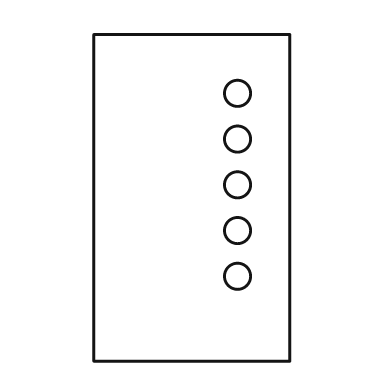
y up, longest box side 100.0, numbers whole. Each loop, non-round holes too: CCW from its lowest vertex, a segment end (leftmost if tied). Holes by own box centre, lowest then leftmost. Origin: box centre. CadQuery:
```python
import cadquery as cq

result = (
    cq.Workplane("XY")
    .moveTo(-30.0, -50.0)
    .lineTo(30.0, -50.0)
    .lineTo(30.0, 50.0)
    .lineTo(-30.0, 50.0)
    .close()
    .moveTo(14.0, -24.0)
    .circle(4.0)
    .moveTo(14.0, -10.0)
    .circle(4.0)
    .moveTo(14.0, 4.0)
    .circle(4.0)
    .moveTo(14.0, 18.0)
    .circle(4.0)
    .moveTo(14.0, 32.0)
    .circle(4.0)
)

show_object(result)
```